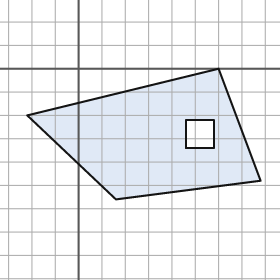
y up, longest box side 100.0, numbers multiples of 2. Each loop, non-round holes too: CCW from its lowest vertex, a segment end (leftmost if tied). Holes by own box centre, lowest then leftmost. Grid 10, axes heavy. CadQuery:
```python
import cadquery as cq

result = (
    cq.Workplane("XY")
    .moveTo(16.0, -56.0)
    .lineTo(78.0, -48.0)
    .lineTo(60.0, 0.0)
    .lineTo(-22.0, -20.0)
    .close()
    .moveTo(46.0, -34.0)
    .lineTo(58.0, -34.0)
    .lineTo(58.0, -22.0)
    .lineTo(46.0, -22.0)
    .close()
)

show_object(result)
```